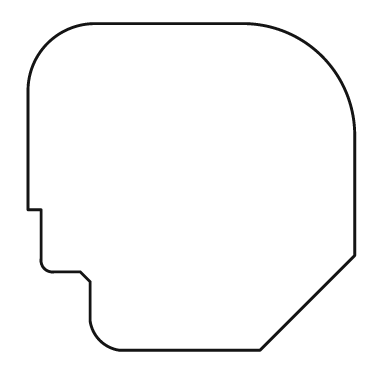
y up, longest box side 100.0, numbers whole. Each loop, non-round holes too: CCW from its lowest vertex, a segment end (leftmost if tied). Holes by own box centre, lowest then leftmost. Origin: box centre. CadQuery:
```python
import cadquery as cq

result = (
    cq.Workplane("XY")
    .moveTo(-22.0, -50.0)
    .lineTo(21.0, -50.0)
    .lineTo(50.0, -21.0)
    .lineTo(50.0, 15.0)
    .threePointArc((40.0, 40.0), (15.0, 50.0))
    .lineTo(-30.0, 50.0)
    .threePointArc((-44.0, 44.0), (-50.0, 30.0))
    .lineTo(-50.0, -7.0)
    .lineTo(-46.0, -7.0)
    .lineTo(-46.0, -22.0)
    .threePointArc((-45.0, -25.0), (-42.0, -26.0))
    .lineTo(-34.0, -26.0)
    .lineTo(-31.0, -29.0)
    .lineTo(-31.0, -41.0)
    .threePointArc((-28.0, -47.0), (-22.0, -50.0))
    .close()
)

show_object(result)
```